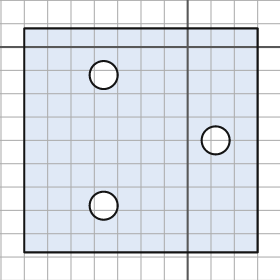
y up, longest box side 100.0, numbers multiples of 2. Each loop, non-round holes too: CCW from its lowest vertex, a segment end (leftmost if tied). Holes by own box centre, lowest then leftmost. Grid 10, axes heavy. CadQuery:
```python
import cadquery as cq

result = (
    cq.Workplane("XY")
    .moveTo(-70.0, -88.0)
    .lineTo(30.0, -88.0)
    .lineTo(30.0, 8.0)
    .lineTo(-70.0, 8.0)
    .close()
    .moveTo(-36.0, -68.0)
    .circle(6.0)
    .moveTo(12.0, -40.0)
    .circle(6.0)
    .moveTo(-36.0, -12.0)
    .circle(6.0)
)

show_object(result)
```